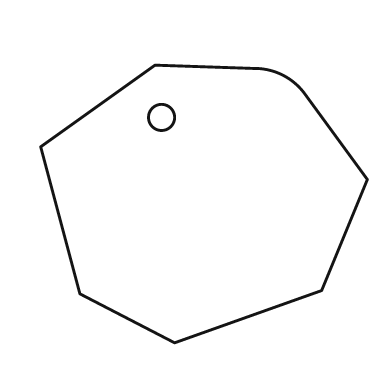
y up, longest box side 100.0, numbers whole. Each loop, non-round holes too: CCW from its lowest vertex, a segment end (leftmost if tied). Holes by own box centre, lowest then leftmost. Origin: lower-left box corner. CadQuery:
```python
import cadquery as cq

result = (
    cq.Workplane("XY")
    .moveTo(41.0, 0.0)
    .lineTo(86.0, 16.0)
    .lineTo(100.0, 50.0)
    .lineTo(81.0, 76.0)
    .threePointArc((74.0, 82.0), (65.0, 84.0))
    .lineTo(35.0, 85.0)
    .lineTo(0.0, 60.0)
    .lineTo(12.0, 15.0)
    .close()
    .moveTo(37.0, 69.0)
    .circle(4.0)
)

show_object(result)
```